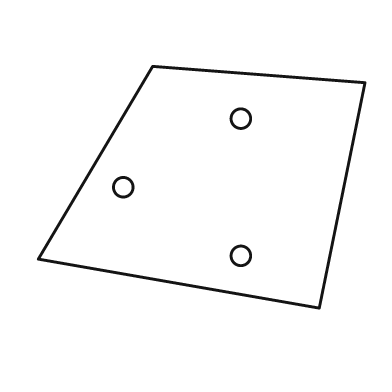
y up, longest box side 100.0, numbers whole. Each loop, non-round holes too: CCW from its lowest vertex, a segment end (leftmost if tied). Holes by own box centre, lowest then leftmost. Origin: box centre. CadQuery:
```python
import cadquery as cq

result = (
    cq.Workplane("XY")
    .moveTo(36.0, -37.0)
    .lineTo(50.0, 32.0)
    .lineTo(-15.0, 37.0)
    .lineTo(-50.0, -22.0)
    .close()
    .moveTo(12.0, -21.0)
    .circle(3.0)
    .moveTo(-24.0, 0.0)
    .circle(3.0)
    .moveTo(12.0, 21.0)
    .circle(3.0)
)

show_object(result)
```